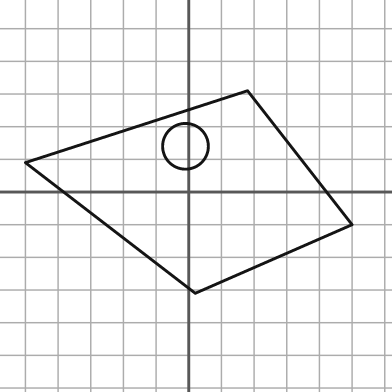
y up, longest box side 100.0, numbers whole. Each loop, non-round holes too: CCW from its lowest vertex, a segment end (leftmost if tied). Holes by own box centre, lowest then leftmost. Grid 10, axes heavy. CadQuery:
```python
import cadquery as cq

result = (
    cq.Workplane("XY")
    .moveTo(2.0, -31.0)
    .lineTo(50.0, -10.0)
    .lineTo(18.0, 31.0)
    .lineTo(-50.0, 9.0)
    .close()
    .moveTo(-1.0, 14.0)
    .circle(7.0)
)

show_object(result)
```